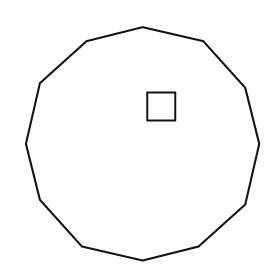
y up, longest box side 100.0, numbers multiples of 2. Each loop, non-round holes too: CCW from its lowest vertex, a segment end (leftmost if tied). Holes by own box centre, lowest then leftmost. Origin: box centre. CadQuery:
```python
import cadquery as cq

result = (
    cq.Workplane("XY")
    .moveTo(0.0, -50.0)
    .lineTo(24.0, -44.0)
    .lineTo(44.0, -26.0)
    .lineTo(50.0, 0.0)
    .lineTo(44.0, 24.0)
    .lineTo(26.0, 44.0)
    .lineTo(0.0, 50.0)
    .lineTo(-24.0, 44.0)
    .lineTo(-44.0, 26.0)
    .lineTo(-50.0, 0.0)
    .lineTo(-44.0, -24.0)
    .lineTo(-26.0, -44.0)
    .close()
    .moveTo(2.0, 10.0)
    .lineTo(14.0, 10.0)
    .lineTo(14.0, 22.0)
    .lineTo(2.0, 22.0)
    .close()
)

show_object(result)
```